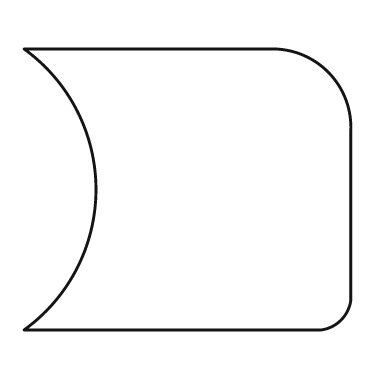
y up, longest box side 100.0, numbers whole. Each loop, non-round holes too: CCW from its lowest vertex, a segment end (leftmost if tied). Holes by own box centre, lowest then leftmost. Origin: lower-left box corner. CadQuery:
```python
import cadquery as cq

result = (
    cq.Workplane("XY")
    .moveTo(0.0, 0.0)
    .lineTo(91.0, 0.0)
    .threePointArc((97.0, 3.0), (100.0, 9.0))
    .lineTo(100.0, 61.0)
    .threePointArc((93.0, 79.0), (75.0, 86.0))
    .lineTo(0.0, 86.0)
    .threePointArc((22.0, 43.0), (0.0, 0.0))
    .close()
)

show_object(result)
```